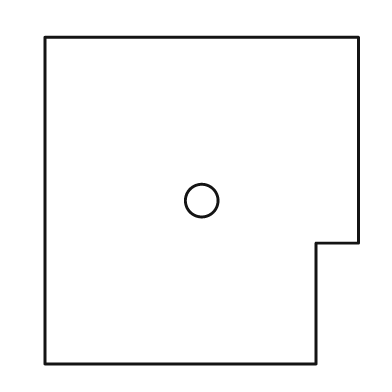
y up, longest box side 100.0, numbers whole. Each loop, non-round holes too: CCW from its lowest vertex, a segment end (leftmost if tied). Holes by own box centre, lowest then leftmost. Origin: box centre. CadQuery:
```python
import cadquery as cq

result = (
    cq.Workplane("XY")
    .moveTo(-48.0, -50.0)
    .lineTo(35.0, -50.0)
    .lineTo(35.0, -13.0)
    .lineTo(48.0, -13.0)
    .lineTo(48.0, 50.0)
    .lineTo(-48.0, 50.0)
    .close()
    .moveTo(0.0, 0.0)
    .circle(5.0)
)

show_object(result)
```